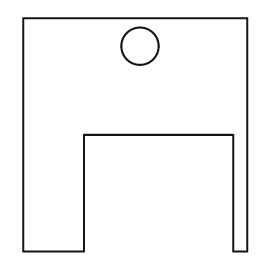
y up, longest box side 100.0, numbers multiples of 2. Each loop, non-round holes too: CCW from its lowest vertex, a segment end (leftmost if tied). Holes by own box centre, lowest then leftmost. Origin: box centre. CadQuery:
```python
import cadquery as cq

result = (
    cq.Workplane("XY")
    .moveTo(-48.0, -50.0)
    .lineTo(-22.0, -50.0)
    .lineTo(-22.0, 0.0)
    .lineTo(42.0, 0.0)
    .lineTo(42.0, -50.0)
    .lineTo(48.0, -50.0)
    .lineTo(48.0, 50.0)
    .lineTo(-48.0, 50.0)
    .close()
    .moveTo(2.0, 38.0)
    .circle(8.0)
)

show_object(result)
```